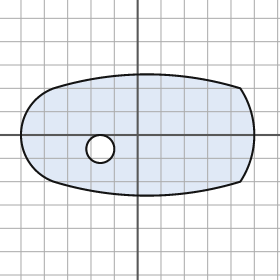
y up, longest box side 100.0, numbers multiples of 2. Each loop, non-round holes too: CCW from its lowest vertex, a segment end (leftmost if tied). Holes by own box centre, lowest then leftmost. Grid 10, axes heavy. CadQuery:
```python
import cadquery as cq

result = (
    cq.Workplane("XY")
    .moveTo(-36.0, -20.0)
    .threePointArc((4.0, -26.0), (44.0, -20.0))
    .threePointArc((50.0, 0.0), (44.0, 20.0))
    .threePointArc((4.0, 26.0), (-36.0, 20.0))
    .threePointArc((-50.0, 0.0), (-36.0, -20.0))
    .close()
    .moveTo(-16.0, -6.0)
    .circle(6.0)
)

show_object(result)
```